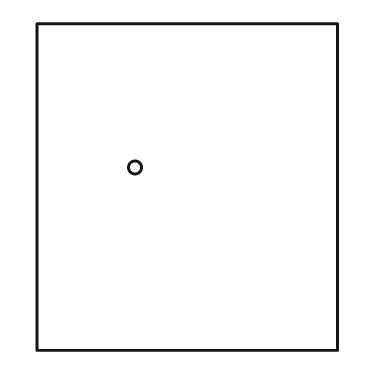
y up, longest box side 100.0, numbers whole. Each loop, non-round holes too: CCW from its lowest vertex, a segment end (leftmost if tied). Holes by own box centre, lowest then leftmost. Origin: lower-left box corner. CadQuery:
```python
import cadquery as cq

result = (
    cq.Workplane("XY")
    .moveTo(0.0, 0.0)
    .lineTo(92.0, 0.0)
    .lineTo(92.0, 100.0)
    .lineTo(0.0, 100.0)
    .close()
    .moveTo(30.0, 56.0)
    .circle(2.0)
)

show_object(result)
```